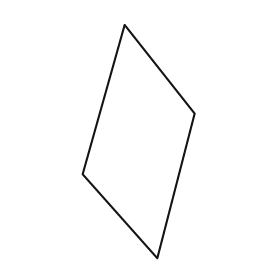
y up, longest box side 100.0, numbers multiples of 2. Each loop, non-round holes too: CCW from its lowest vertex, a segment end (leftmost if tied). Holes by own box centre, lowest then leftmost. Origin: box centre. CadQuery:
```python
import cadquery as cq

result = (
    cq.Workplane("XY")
    .moveTo(8.0, -50.0)
    .lineTo(24.0, 12.0)
    .lineTo(-6.0, 50.0)
    .lineTo(-24.0, -14.0)
    .close()
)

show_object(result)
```